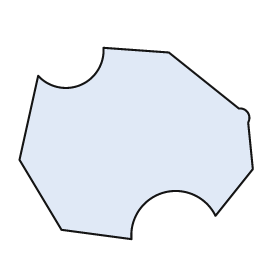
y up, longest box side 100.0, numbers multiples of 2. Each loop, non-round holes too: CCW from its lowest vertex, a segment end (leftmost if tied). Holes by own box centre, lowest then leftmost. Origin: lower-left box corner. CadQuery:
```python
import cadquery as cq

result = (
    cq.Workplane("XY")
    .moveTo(48.0, 0.0)
    .threePointArc((62.0, 20.0), (84.0, 10.0))
    .lineTo(100.0, 30.0)
    .lineTo(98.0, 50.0)
    .threePointArc((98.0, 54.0), (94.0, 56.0))
    .lineTo(64.0, 80.0)
    .lineTo(36.0, 82.0)
    .threePointArc((26.0, 66.0), (8.0, 70.0))
    .lineTo(0.0, 34.0)
    .lineTo(18.0, 4.0)
    .close()
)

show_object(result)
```